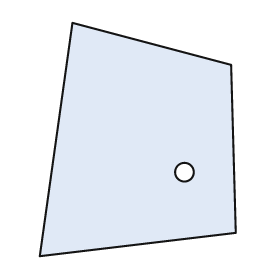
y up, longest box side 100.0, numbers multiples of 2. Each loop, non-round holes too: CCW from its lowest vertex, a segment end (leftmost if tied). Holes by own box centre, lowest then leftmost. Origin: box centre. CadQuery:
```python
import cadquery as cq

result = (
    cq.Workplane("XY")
    .moveTo(-42.0, -50.0)
    .lineTo(42.0, -40.0)
    .lineTo(40.0, 32.0)
    .lineTo(-28.0, 50.0)
    .close()
    .moveTo(20.0, -14.0)
    .circle(4.0)
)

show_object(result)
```